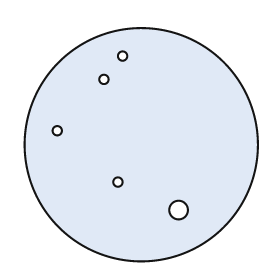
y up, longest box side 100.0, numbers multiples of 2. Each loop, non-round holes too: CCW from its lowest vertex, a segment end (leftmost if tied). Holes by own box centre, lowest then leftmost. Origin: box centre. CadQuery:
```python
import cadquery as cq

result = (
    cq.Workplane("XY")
    .moveTo(0.0, 0.0)
    .circle(50.0)
    .moveTo(16.0, -28.0)
    .circle(4.0)
    .moveTo(-10.0, -16.0)
    .circle(2.0)
    .moveTo(-36.0, 6.0)
    .circle(2.0)
    .moveTo(-16.0, 28.0)
    .circle(2.0)
    .moveTo(-8.0, 38.0)
    .circle(2.0)
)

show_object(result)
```